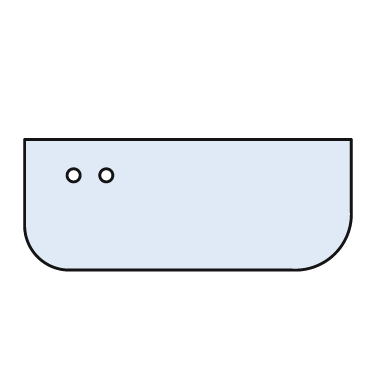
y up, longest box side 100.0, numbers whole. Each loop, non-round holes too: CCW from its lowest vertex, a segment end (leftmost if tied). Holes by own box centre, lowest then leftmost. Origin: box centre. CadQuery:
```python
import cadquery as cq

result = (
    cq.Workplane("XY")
    .moveTo(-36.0, -20.0)
    .lineTo(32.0, -20.0)
    .threePointArc((45.0, -15.0), (50.0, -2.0))
    .lineTo(50.0, 20.0)
    .lineTo(-50.0, 20.0)
    .lineTo(-50.0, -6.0)
    .threePointArc((-46.0, -16.0), (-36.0, -20.0))
    .close()
    .moveTo(-35.0, 9.0)
    .circle(2.0)
    .moveTo(-25.0, 9.0)
    .circle(2.0)
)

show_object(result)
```